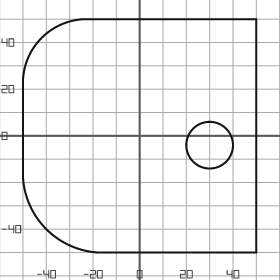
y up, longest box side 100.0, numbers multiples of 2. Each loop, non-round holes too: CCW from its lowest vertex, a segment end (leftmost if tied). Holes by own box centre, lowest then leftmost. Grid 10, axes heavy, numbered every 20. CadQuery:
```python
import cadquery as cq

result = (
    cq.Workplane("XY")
    .moveTo(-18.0, -50.0)
    .lineTo(50.0, -50.0)
    .lineTo(50.0, 50.0)
    .lineTo(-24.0, 50.0)
    .threePointArc((-42.0, 42.0), (-50.0, 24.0))
    .lineTo(-50.0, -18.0)
    .threePointArc((-40.0, -40.0), (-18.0, -50.0))
    .close()
    .moveTo(30.0, -4.0)
    .circle(10.0)
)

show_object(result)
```